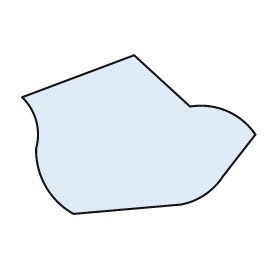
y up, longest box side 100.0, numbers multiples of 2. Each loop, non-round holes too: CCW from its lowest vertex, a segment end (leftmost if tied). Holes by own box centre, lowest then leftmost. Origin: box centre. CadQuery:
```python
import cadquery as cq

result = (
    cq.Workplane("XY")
    .moveTo(-28.0, -34.0)
    .lineTo(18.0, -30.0)
    .threePointArc((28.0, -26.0), (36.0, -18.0))
    .lineTo(50.0, 0.0)
    .threePointArc((38.0, 10.0), (22.0, 12.0))
    .lineTo(-2.0, 34.0)
    .lineTo(-50.0, 16.0)
    .threePointArc((-44.0, 6.0), (-44.0, -6.0))
    .threePointArc((-40.0, -22.0), (-28.0, -34.0))
    .close()
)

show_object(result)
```